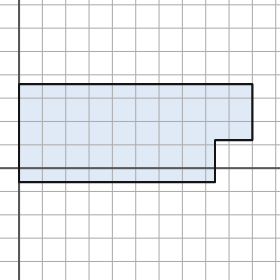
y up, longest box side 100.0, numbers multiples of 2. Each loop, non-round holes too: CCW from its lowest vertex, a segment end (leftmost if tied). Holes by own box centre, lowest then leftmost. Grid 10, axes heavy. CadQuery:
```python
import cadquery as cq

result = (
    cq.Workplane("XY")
    .moveTo(0.0, -6.0)
    .lineTo(84.0, -6.0)
    .lineTo(84.0, 12.0)
    .lineTo(100.0, 12.0)
    .lineTo(100.0, 36.0)
    .lineTo(0.0, 36.0)
    .close()
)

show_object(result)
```